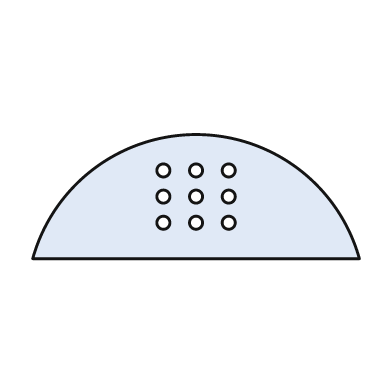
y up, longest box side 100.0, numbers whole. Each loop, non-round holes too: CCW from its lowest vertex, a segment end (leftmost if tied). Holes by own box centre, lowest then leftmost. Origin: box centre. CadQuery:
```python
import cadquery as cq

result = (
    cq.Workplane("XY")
    .moveTo(-50.0, -19.0)
    .lineTo(50.0, -19.0)
    .threePointArc((0.0, 19.0), (-50.0, -19.0))
    .close()
    .moveTo(-10.0, -8.0)
    .circle(2.0)
    .moveTo(0.0, -8.0)
    .circle(2.0)
    .moveTo(10.0, -8.0)
    .circle(2.0)
    .moveTo(-10.0, 0.0)
    .circle(2.0)
    .moveTo(0.0, 0.0)
    .circle(2.0)
    .moveTo(10.0, 0.0)
    .circle(2.0)
    .moveTo(-10.0, 8.0)
    .circle(2.0)
    .moveTo(0.0, 8.0)
    .circle(2.0)
    .moveTo(10.0, 8.0)
    .circle(2.0)
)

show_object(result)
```